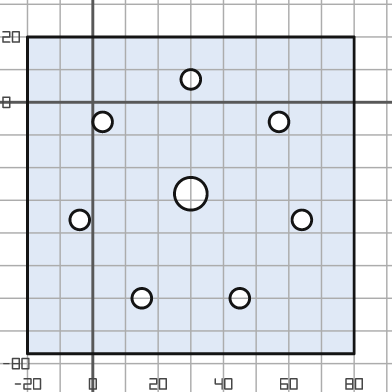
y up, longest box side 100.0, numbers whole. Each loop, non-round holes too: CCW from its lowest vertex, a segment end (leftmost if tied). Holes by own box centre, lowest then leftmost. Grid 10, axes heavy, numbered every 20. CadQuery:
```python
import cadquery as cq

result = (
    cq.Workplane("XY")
    .moveTo(-20.0, -77.0)
    .lineTo(80.0, -77.0)
    .lineTo(80.0, 20.0)
    .lineTo(-20.0, 20.0)
    .close()
    .moveTo(15.0, -60.0)
    .circle(3.0)
    .moveTo(45.0, -60.0)
    .circle(3.0)
    .moveTo(-4.0, -36.0)
    .circle(3.0)
    .moveTo(64.0, -36.0)
    .circle(3.0)
    .moveTo(30.0, -28.0)
    .circle(5.0)
    .moveTo(3.0, -6.0)
    .circle(3.0)
    .moveTo(57.0, -6.0)
    .circle(3.0)
    .moveTo(30.0, 7.0)
    .circle(3.0)
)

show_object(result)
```